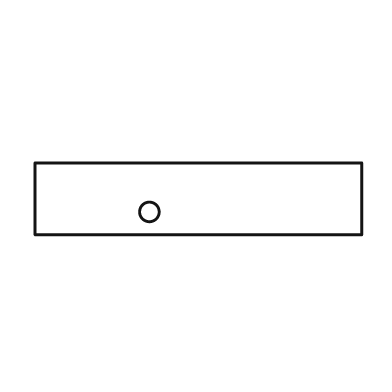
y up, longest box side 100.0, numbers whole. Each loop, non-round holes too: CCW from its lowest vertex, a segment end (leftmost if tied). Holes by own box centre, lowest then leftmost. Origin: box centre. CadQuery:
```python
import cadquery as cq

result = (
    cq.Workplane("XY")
    .moveTo(-50.0, -11.0)
    .lineTo(50.0, -11.0)
    .lineTo(50.0, 11.0)
    .lineTo(-50.0, 11.0)
    .close()
    .moveTo(-15.0, -4.0)
    .circle(3.0)
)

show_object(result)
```